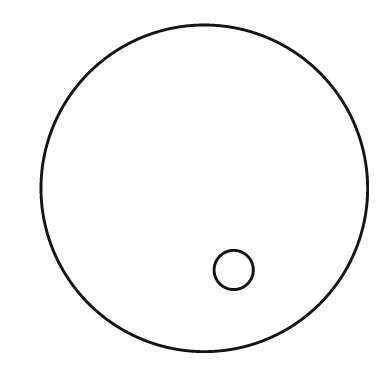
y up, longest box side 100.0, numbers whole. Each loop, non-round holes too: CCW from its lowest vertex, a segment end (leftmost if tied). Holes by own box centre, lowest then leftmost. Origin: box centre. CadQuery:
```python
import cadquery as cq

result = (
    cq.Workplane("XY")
    .moveTo(0.0, 0.0)
    .circle(50.0)
    .moveTo(9.0, -25.0)
    .circle(6.0)
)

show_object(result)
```